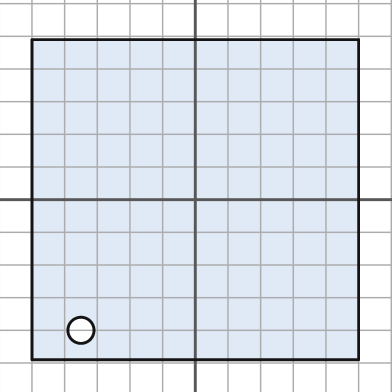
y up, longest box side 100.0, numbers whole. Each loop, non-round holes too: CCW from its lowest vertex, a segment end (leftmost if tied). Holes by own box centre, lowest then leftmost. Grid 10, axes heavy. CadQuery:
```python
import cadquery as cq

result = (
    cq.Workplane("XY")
    .moveTo(-50.0, -49.0)
    .lineTo(50.0, -49.0)
    .lineTo(50.0, 49.0)
    .lineTo(-50.0, 49.0)
    .close()
    .moveTo(-35.0, -40.0)
    .circle(4.0)
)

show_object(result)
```